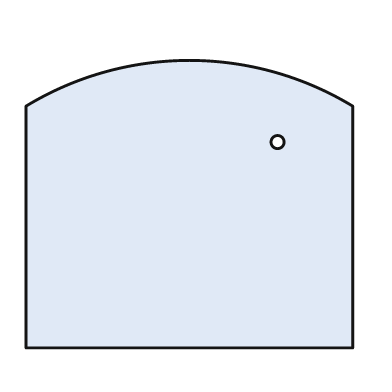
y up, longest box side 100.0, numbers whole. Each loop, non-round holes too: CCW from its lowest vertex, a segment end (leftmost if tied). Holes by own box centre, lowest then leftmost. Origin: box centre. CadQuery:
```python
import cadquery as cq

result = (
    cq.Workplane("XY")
    .moveTo(-50.0, -44.0)
    .lineTo(50.0, -44.0)
    .lineTo(50.0, 30.0)
    .threePointArc((0.0, 44.0), (-50.0, 30.0))
    .close()
    .moveTo(27.0, 19.0)
    .circle(2.0)
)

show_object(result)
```